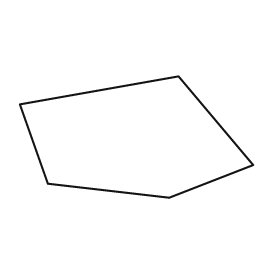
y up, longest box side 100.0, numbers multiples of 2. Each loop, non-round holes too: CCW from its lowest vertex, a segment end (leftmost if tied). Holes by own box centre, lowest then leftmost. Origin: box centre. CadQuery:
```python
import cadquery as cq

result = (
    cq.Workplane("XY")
    .moveTo(14.0, -26.0)
    .lineTo(50.0, -12.0)
    .lineTo(18.0, 26.0)
    .lineTo(-50.0, 14.0)
    .lineTo(-38.0, -20.0)
    .close()
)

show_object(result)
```